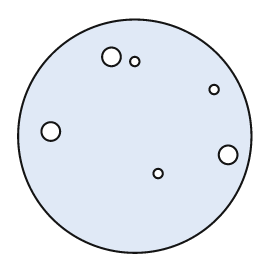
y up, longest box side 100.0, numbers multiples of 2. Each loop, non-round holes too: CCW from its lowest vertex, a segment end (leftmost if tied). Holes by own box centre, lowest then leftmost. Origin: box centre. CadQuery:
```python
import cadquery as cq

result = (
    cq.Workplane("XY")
    .moveTo(0.0, 0.0)
    .circle(50.0)
    .moveTo(10.0, -16.0)
    .circle(2.0)
    .moveTo(40.0, -8.0)
    .circle(4.0)
    .moveTo(-36.0, 2.0)
    .circle(4.0)
    .moveTo(34.0, 20.0)
    .circle(2.0)
    .moveTo(0.0, 32.0)
    .circle(2.0)
    .moveTo(-10.0, 34.0)
    .circle(4.0)
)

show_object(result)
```